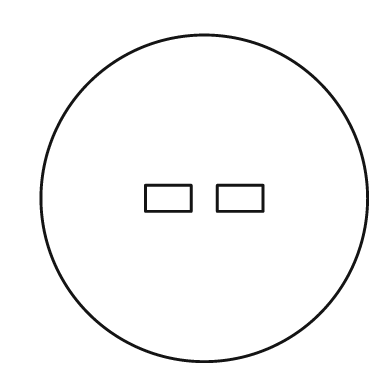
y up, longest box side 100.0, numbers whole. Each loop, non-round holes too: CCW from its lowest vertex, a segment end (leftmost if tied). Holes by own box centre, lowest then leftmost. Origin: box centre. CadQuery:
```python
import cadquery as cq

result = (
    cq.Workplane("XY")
    .moveTo(0.0, 0.0)
    .circle(50.0)
    .moveTo(-18.0, -4.0)
    .lineTo(-4.0, -4.0)
    .lineTo(-4.0, 4.0)
    .lineTo(-18.0, 4.0)
    .close()
    .moveTo(4.0, -4.0)
    .lineTo(18.0, -4.0)
    .lineTo(18.0, 4.0)
    .lineTo(4.0, 4.0)
    .close()
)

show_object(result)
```